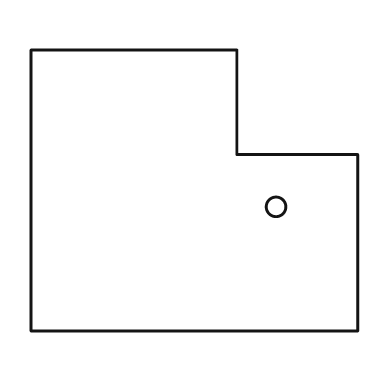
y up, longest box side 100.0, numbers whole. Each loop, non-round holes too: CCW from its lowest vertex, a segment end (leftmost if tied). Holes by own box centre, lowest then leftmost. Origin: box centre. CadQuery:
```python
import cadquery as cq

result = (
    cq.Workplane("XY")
    .moveTo(-50.0, -43.0)
    .lineTo(50.0, -43.0)
    .lineTo(50.0, 11.0)
    .lineTo(13.0, 11.0)
    .lineTo(13.0, 43.0)
    .lineTo(-50.0, 43.0)
    .close()
    .moveTo(25.0, -5.0)
    .circle(3.0)
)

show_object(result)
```